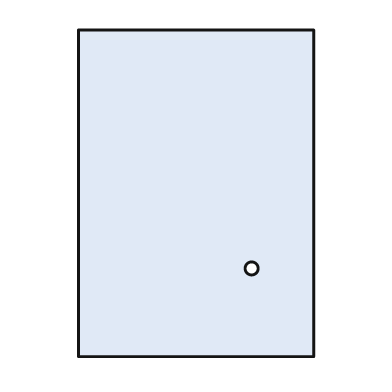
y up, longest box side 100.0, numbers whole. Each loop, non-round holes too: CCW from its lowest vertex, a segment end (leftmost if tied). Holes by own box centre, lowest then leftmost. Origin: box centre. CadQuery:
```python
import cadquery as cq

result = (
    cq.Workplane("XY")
    .moveTo(-36.0, -50.0)
    .lineTo(36.0, -50.0)
    .lineTo(36.0, 50.0)
    .lineTo(-36.0, 50.0)
    .close()
    .moveTo(17.0, -23.0)
    .circle(2.0)
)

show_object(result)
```